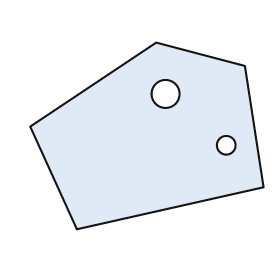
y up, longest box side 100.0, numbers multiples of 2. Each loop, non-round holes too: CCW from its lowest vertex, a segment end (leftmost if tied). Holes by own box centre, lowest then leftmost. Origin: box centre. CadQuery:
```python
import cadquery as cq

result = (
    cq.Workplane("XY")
    .moveTo(-30.0, -40.0)
    .lineTo(50.0, -22.0)
    .lineTo(42.0, 30.0)
    .lineTo(4.0, 40.0)
    .lineTo(-50.0, 4.0)
    .close()
    .moveTo(34.0, -4.0)
    .circle(4.0)
    .moveTo(8.0, 18.0)
    .circle(6.0)
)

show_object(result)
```